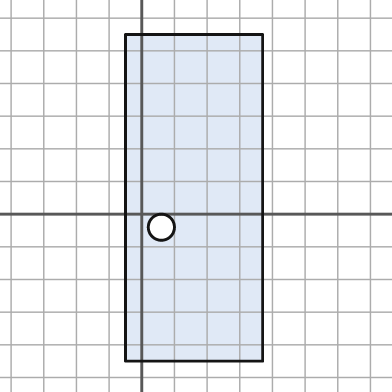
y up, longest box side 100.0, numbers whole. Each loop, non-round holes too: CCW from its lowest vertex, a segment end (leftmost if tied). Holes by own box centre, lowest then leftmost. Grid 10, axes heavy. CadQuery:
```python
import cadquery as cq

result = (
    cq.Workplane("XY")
    .moveTo(-5.0, -45.0)
    .lineTo(37.0, -45.0)
    .lineTo(37.0, 55.0)
    .lineTo(-5.0, 55.0)
    .close()
    .moveTo(6.0, -4.0)
    .circle(4.0)
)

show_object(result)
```